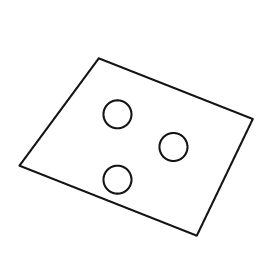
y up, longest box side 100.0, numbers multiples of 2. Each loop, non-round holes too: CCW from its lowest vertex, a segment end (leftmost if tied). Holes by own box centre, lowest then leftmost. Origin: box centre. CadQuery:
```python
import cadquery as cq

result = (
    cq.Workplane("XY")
    .moveTo(26.0, -38.0)
    .lineTo(50.0, 12.0)
    .lineTo(-16.0, 38.0)
    .lineTo(-50.0, -8.0)
    .close()
    .moveTo(-8.0, -14.0)
    .circle(6.0)
    .moveTo(16.0, 0.0)
    .circle(6.0)
    .moveTo(-8.0, 14.0)
    .circle(6.0)
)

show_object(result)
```